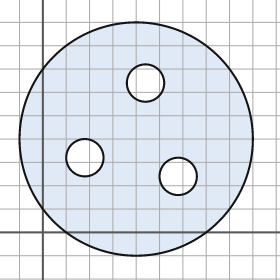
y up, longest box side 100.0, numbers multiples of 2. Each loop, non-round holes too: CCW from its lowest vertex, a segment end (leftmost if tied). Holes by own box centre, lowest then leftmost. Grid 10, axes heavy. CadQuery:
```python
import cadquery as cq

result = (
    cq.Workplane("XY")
    .moveTo(40.0, 40.0)
    .circle(50.0)
    .moveTo(58.0, 24.0)
    .circle(8.0)
    .moveTo(18.0, 32.0)
    .circle(8.0)
    .moveTo(44.0, 64.0)
    .circle(8.0)
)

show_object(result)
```